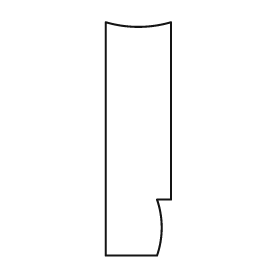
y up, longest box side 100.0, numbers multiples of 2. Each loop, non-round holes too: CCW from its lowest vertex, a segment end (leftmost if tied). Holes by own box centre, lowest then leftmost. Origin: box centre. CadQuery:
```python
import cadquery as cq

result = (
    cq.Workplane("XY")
    .moveTo(-14.0, -50.0)
    .lineTo(8.0, -50.0)
    .threePointArc((10.0, -38.0), (8.0, -26.0))
    .lineTo(14.0, -26.0)
    .lineTo(14.0, 50.0)
    .threePointArc((0.0, 48.0), (-14.0, 50.0))
    .close()
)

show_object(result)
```